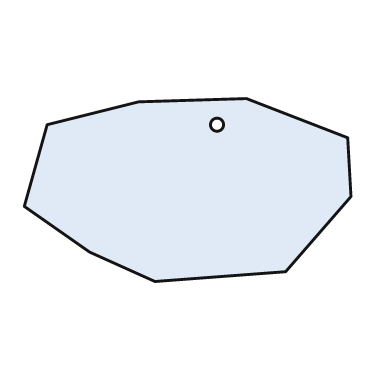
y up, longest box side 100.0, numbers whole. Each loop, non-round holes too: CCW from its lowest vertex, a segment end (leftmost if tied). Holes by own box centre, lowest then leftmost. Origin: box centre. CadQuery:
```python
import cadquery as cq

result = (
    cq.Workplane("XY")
    .moveTo(-10.0, -28.0)
    .lineTo(30.0, -25.0)
    .lineTo(50.0, -2.0)
    .lineTo(49.0, 16.0)
    .lineTo(18.0, 28.0)
    .lineTo(-15.0, 27.0)
    .lineTo(-43.0, 20.0)
    .lineTo(-50.0, -5.0)
    .lineTo(-30.0, -19.0)
    .close()
    .moveTo(9.0, 20.0)
    .circle(2.0)
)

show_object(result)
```